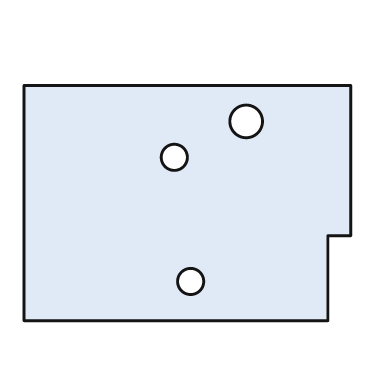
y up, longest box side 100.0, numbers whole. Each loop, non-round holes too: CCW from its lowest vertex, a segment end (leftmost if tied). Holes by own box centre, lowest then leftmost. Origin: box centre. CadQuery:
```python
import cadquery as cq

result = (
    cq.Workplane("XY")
    .moveTo(-50.0, -36.0)
    .lineTo(43.0, -36.0)
    .lineTo(43.0, -10.0)
    .lineTo(50.0, -10.0)
    .lineTo(50.0, 36.0)
    .lineTo(-50.0, 36.0)
    .close()
    .moveTo(1.0, -24.0)
    .circle(4.0)
    .moveTo(-4.0, 14.0)
    .circle(4.0)
    .moveTo(18.0, 25.0)
    .circle(5.0)
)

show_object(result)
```